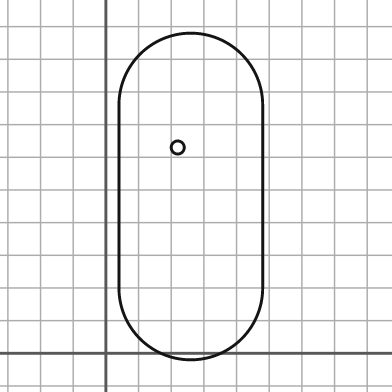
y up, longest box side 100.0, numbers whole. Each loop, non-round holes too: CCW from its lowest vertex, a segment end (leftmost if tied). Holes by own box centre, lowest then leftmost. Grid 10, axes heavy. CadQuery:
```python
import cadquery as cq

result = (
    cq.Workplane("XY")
    .moveTo(4.0, 20.0)
    .threePointArc((26.0, -2.0), (48.0, 20.0))
    .lineTo(48.0, 76.0)
    .threePointArc((26.0, 98.0), (4.0, 76.0))
    .close()
    .moveTo(22.0, 63.0)
    .circle(2.0)
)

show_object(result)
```